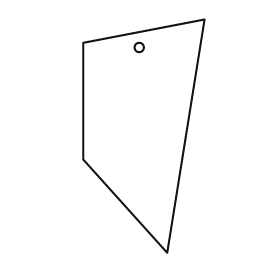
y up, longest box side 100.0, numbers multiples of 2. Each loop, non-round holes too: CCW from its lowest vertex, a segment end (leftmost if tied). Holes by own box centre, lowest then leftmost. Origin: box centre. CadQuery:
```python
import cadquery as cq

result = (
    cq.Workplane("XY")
    .moveTo(10.0, -50.0)
    .lineTo(26.0, 50.0)
    .lineTo(-26.0, 40.0)
    .lineTo(-26.0, -10.0)
    .close()
    .moveTo(-2.0, 38.0)
    .circle(2.0)
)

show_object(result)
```